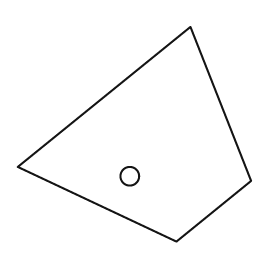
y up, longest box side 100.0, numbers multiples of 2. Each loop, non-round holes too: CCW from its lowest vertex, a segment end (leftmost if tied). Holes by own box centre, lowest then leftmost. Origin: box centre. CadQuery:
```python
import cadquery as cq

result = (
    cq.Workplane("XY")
    .moveTo(18.0, -46.0)
    .lineTo(50.0, -20.0)
    .lineTo(24.0, 46.0)
    .lineTo(-50.0, -14.0)
    .close()
    .moveTo(-2.0, -18.0)
    .circle(4.0)
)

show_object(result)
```